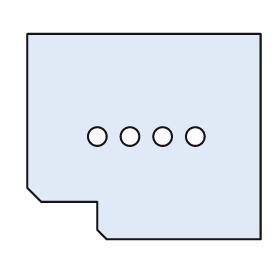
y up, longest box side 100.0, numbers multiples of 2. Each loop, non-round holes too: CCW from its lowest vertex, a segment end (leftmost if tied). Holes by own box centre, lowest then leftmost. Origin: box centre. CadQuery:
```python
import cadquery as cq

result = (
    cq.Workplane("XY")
    .moveTo(-16.0, -44.0)
    .lineTo(50.0, -44.0)
    .lineTo(50.0, 44.0)
    .lineTo(-50.0, 44.0)
    .lineTo(-50.0, -22.0)
    .lineTo(-44.0, -28.0)
    .lineTo(-20.0, -28.0)
    .lineTo(-20.0, -40.0)
    .close()
    .moveTo(-20.0, 0.0)
    .circle(4.0)
    .moveTo(-6.0, 0.0)
    .circle(4.0)
    .moveTo(8.0, 0.0)
    .circle(4.0)
    .moveTo(22.0, 0.0)
    .circle(4.0)
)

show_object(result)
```